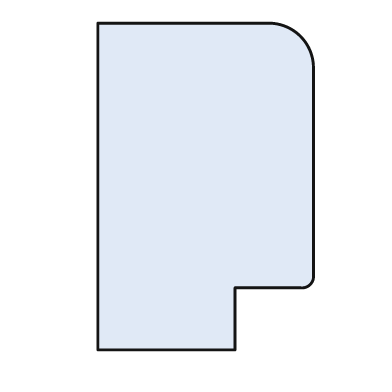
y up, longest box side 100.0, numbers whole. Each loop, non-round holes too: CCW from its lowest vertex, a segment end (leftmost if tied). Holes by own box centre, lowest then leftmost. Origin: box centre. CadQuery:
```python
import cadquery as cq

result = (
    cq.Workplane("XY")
    .moveTo(-33.0, -50.0)
    .lineTo(9.0, -50.0)
    .lineTo(9.0, -31.0)
    .lineTo(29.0, -31.0)
    .threePointArc((32.0, -30.0), (33.0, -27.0))
    .lineTo(33.0, 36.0)
    .threePointArc((29.0, 46.0), (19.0, 50.0))
    .lineTo(-33.0, 50.0)
    .close()
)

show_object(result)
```